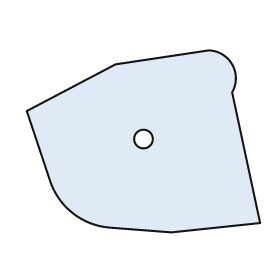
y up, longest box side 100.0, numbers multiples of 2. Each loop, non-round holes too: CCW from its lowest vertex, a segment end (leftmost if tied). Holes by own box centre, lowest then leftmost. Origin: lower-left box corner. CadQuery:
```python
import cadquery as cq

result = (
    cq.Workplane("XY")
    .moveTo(62.0, 0.0)
    .lineTo(100.0, 4.0)
    .lineTo(88.0, 60.0)
    .threePointArc((88.0, 72.0), (78.0, 78.0))
    .lineTo(38.0, 72.0)
    .lineTo(0.0, 52.0)
    .lineTo(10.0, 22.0)
    .threePointArc((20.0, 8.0), (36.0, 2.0))
    .close()
    .moveTo(50.0, 40.0)
    .circle(4.0)
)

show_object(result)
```